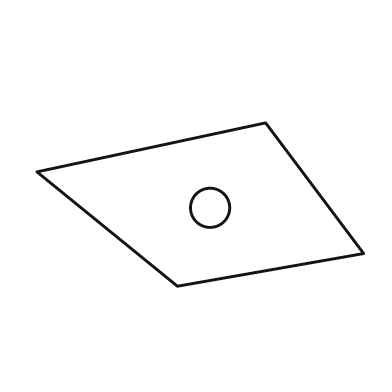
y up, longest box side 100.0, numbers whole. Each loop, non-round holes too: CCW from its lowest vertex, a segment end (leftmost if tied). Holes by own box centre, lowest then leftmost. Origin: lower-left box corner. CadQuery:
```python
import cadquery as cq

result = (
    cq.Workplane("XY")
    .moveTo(43.0, 0.0)
    .lineTo(100.0, 10.0)
    .lineTo(70.0, 50.0)
    .lineTo(0.0, 35.0)
    .close()
    .moveTo(53.0, 24.0)
    .circle(6.0)
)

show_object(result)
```